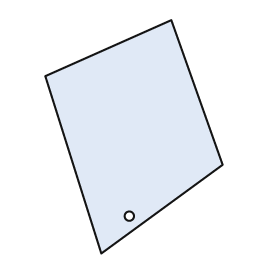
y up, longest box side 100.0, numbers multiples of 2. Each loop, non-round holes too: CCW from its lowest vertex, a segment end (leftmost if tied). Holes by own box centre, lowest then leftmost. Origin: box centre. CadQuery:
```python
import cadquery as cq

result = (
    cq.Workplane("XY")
    .moveTo(-14.0, -50.0)
    .lineTo(38.0, -12.0)
    .lineTo(16.0, 50.0)
    .lineTo(-38.0, 26.0)
    .close()
    .moveTo(-2.0, -34.0)
    .circle(2.0)
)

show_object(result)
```